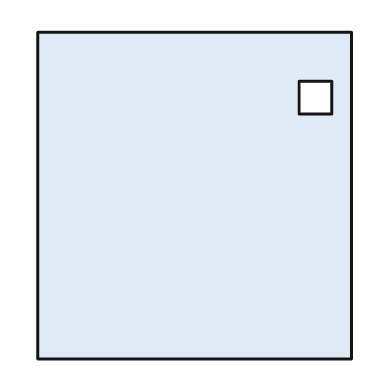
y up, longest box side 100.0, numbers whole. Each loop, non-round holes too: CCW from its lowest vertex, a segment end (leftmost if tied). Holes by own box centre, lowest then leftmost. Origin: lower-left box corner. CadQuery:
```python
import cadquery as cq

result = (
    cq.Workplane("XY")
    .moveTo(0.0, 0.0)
    .lineTo(96.0, 0.0)
    .lineTo(96.0, 100.0)
    .lineTo(0.0, 100.0)
    .close()
    .moveTo(80.0, 75.0)
    .lineTo(90.0, 75.0)
    .lineTo(90.0, 85.0)
    .lineTo(80.0, 85.0)
    .close()
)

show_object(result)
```